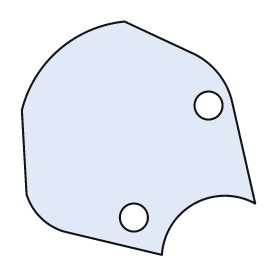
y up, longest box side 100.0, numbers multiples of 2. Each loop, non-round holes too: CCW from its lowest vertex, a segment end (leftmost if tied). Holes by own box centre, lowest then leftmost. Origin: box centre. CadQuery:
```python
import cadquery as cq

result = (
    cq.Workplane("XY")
    .moveTo(10.0, -50.0)
    .threePointArc((24.0, -28.0), (50.0, -28.0))
    .lineTo(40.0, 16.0)
    .threePointArc((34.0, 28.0), (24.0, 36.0))
    .lineTo(-6.0, 50.0)
    .threePointArc((-34.0, 38.0), (-50.0, 12.0))
    .lineTo(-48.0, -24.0)
    .threePointArc((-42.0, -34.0), (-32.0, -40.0))
    .close()
    .moveTo(-2.0, -34.0)
    .circle(6.0)
    .moveTo(30.0, 14.0)
    .circle(6.0)
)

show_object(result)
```